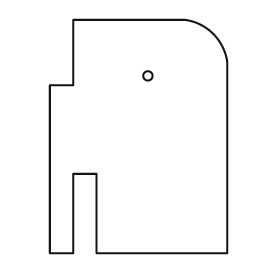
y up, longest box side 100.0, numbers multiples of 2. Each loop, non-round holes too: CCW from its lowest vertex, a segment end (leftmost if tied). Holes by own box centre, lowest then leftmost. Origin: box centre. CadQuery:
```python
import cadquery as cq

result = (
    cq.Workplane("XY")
    .moveTo(-38.0, -50.0)
    .lineTo(-28.0, -50.0)
    .lineTo(-28.0, -16.0)
    .lineTo(-18.0, -16.0)
    .lineTo(-18.0, -50.0)
    .lineTo(38.0, -50.0)
    .lineTo(38.0, 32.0)
    .threePointArc((32.0, 44.0), (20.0, 50.0))
    .lineTo(-28.0, 50.0)
    .lineTo(-28.0, 22.0)
    .lineTo(-38.0, 22.0)
    .close()
    .moveTo(4.0, 26.0)
    .circle(2.0)
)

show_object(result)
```